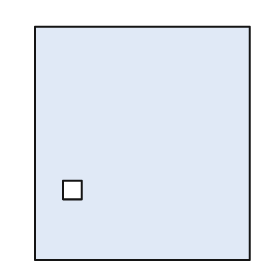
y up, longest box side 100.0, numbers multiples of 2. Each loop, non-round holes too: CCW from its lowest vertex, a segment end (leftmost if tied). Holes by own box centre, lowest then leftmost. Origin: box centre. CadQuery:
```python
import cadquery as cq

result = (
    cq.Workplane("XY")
    .moveTo(-46.0, -50.0)
    .lineTo(46.0, -50.0)
    .lineTo(46.0, 50.0)
    .lineTo(-46.0, 50.0)
    .close()
    .moveTo(-34.0, -24.0)
    .lineTo(-26.0, -24.0)
    .lineTo(-26.0, -16.0)
    .lineTo(-34.0, -16.0)
    .close()
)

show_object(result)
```